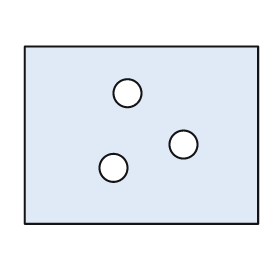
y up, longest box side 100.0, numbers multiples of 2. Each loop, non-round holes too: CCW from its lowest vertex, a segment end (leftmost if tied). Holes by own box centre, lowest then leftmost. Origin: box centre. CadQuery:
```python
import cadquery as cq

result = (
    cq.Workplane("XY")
    .moveTo(-50.0, -38.0)
    .lineTo(50.0, -38.0)
    .lineTo(50.0, 38.0)
    .lineTo(-50.0, 38.0)
    .close()
    .moveTo(-12.0, -14.0)
    .circle(6.0)
    .moveTo(18.0, -4.0)
    .circle(6.0)
    .moveTo(-6.0, 18.0)
    .circle(6.0)
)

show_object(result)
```